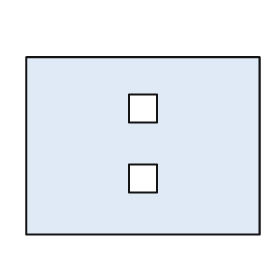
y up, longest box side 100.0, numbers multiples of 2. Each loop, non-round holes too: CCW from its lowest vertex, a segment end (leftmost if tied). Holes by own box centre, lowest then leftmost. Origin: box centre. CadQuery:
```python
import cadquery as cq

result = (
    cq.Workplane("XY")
    .moveTo(-50.0, -38.0)
    .lineTo(50.0, -38.0)
    .lineTo(50.0, 38.0)
    .lineTo(-50.0, 38.0)
    .close()
    .moveTo(-6.0, -20.0)
    .lineTo(6.0, -20.0)
    .lineTo(6.0, -8.0)
    .lineTo(-6.0, -8.0)
    .close()
    .moveTo(-6.0, 10.0)
    .lineTo(6.0, 10.0)
    .lineTo(6.0, 22.0)
    .lineTo(-6.0, 22.0)
    .close()
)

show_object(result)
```